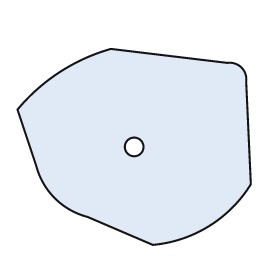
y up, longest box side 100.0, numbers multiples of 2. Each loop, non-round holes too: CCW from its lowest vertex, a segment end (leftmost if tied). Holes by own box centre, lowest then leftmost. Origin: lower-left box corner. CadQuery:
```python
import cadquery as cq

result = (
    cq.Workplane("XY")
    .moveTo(58.0, 0.0)
    .threePointArc((82.0, 8.0), (100.0, 26.0))
    .lineTo(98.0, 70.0)
    .threePointArc((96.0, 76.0), (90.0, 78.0))
    .lineTo(40.0, 84.0)
    .threePointArc((18.0, 74.0), (0.0, 58.0))
    .lineTo(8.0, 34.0)
    .threePointArc((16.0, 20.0), (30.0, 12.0))
    .close()
    .moveTo(50.0, 42.0)
    .circle(4.0)
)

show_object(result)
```